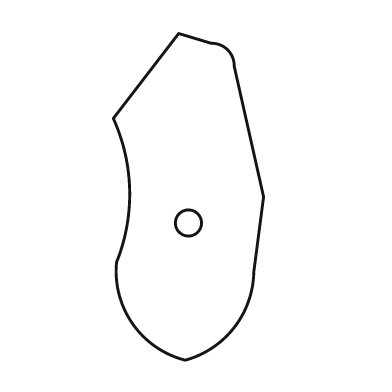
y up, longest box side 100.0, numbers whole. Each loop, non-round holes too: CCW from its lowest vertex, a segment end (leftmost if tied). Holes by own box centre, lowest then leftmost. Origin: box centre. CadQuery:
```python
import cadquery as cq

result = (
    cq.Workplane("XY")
    .moveTo(-1.0, -50.0)
    .threePointArc((14.0, -40.0), (20.0, -23.0))
    .lineTo(23.0, 0.0)
    .lineTo(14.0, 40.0)
    .threePointArc((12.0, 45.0), (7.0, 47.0))
    .lineTo(-3.0, 50.0)
    .lineTo(-23.0, 24.0)
    .threePointArc((-18.0, 2.0), (-22.0, -20.0))
    .threePointArc((-17.0, -39.0), (-1.0, -50.0))
    .close()
    .moveTo(0.0, -8.0)
    .circle(4.0)
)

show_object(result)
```